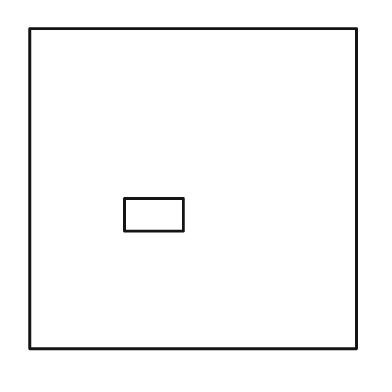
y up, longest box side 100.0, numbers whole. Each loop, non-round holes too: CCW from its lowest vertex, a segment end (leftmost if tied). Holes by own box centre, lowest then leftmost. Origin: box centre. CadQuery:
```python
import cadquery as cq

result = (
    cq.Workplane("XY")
    .moveTo(-50.0, -49.0)
    .lineTo(50.0, -49.0)
    .lineTo(50.0, 49.0)
    .lineTo(-50.0, 49.0)
    .close()
    .moveTo(-21.0, -13.0)
    .lineTo(-3.0, -13.0)
    .lineTo(-3.0, -3.0)
    .lineTo(-21.0, -3.0)
    .close()
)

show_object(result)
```